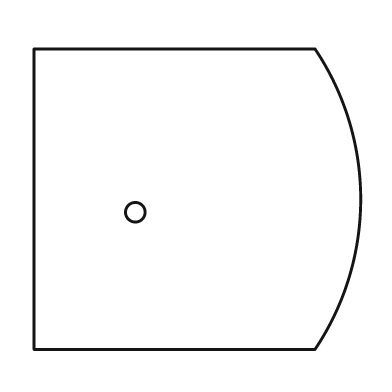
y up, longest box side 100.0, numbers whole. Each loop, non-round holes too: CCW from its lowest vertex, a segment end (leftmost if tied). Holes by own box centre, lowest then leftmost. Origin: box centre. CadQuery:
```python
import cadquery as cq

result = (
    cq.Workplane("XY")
    .moveTo(-50.0, -46.0)
    .lineTo(36.0, -46.0)
    .threePointArc((50.0, 0.0), (36.0, 46.0))
    .lineTo(-50.0, 46.0)
    .close()
    .moveTo(-19.0, -4.0)
    .circle(3.0)
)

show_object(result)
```